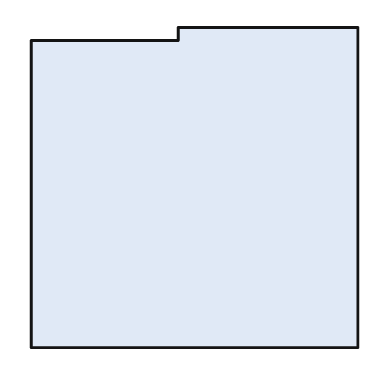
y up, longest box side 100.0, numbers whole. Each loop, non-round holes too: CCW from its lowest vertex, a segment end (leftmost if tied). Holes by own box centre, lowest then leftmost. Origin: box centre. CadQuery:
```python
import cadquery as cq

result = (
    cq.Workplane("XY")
    .moveTo(-50.0, -49.0)
    .lineTo(50.0, -49.0)
    .lineTo(50.0, 49.0)
    .lineTo(-5.0, 49.0)
    .lineTo(-5.0, 45.0)
    .lineTo(-50.0, 45.0)
    .close()
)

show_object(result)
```